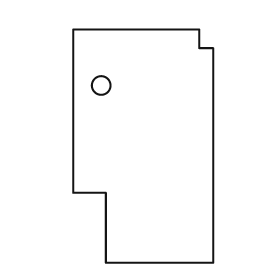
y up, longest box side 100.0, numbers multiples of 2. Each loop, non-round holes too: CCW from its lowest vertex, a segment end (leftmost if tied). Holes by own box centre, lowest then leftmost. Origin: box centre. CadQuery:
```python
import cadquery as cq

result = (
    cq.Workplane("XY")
    .moveTo(-16.0, -50.0)
    .lineTo(30.0, -50.0)
    .lineTo(30.0, 42.0)
    .lineTo(24.0, 42.0)
    .lineTo(24.0, 50.0)
    .lineTo(-30.0, 50.0)
    .lineTo(-30.0, -20.0)
    .lineTo(-16.0, -20.0)
    .close()
    .moveTo(-18.0, 26.0)
    .circle(4.0)
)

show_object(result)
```